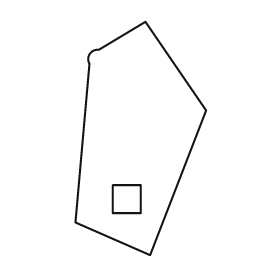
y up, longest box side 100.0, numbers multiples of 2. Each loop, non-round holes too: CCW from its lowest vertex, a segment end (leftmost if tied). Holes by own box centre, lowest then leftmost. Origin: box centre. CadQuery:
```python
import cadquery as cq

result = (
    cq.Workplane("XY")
    .moveTo(4.0, -50.0)
    .lineTo(28.0, 12.0)
    .lineTo(2.0, 50.0)
    .lineTo(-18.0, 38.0)
    .threePointArc((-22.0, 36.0), (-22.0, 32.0))
    .lineTo(-28.0, -36.0)
    .close()
    .moveTo(-12.0, -32.0)
    .lineTo(0.0, -32.0)
    .lineTo(0.0, -20.0)
    .lineTo(-12.0, -20.0)
    .close()
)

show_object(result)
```